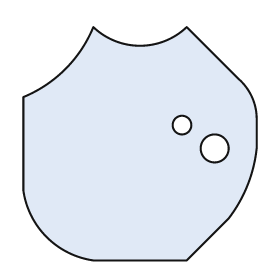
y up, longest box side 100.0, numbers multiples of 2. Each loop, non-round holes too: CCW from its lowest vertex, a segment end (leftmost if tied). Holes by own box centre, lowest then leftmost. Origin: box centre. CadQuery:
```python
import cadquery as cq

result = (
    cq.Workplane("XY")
    .moveTo(-20.0, -50.0)
    .lineTo(20.0, -50.0)
    .lineTo(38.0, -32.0)
    .threePointArc((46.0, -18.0), (50.0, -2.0))
    .lineTo(50.0, 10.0)
    .threePointArc((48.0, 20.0), (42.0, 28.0))
    .lineTo(20.0, 50.0)
    .threePointArc((0.0, 42.0), (-20.0, 50.0))
    .threePointArc((-32.0, 32.0), (-50.0, 20.0))
    .lineTo(-50.0, -20.0)
    .threePointArc((-40.0, -40.0), (-20.0, -50.0))
    .close()
    .moveTo(32.0, -2.0)
    .circle(6.0)
    .moveTo(18.0, 8.0)
    .circle(4.0)
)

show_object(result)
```